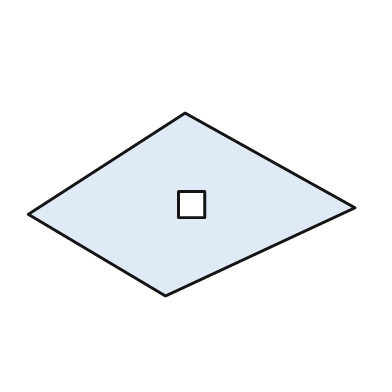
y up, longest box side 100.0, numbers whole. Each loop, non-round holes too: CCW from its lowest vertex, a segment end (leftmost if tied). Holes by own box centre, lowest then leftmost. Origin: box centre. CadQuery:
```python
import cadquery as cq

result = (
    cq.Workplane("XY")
    .moveTo(-8.0, -28.0)
    .lineTo(50.0, -1.0)
    .lineTo(-2.0, 28.0)
    .lineTo(-50.0, -3.0)
    .close()
    .moveTo(-4.0, -4.0)
    .lineTo(4.0, -4.0)
    .lineTo(4.0, 4.0)
    .lineTo(-4.0, 4.0)
    .close()
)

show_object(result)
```